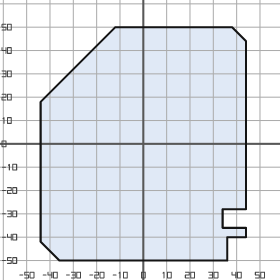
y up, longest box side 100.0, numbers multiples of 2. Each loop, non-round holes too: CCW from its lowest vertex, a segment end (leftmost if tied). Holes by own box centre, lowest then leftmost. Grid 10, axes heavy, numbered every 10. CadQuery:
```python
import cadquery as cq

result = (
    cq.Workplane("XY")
    .moveTo(-36.0, -50.0)
    .lineTo(36.0, -50.0)
    .lineTo(36.0, -40.0)
    .lineTo(44.0, -40.0)
    .lineTo(44.0, -36.0)
    .lineTo(34.0, -36.0)
    .lineTo(34.0, -28.0)
    .lineTo(44.0, -28.0)
    .lineTo(44.0, 44.0)
    .lineTo(38.0, 50.0)
    .lineTo(-12.0, 50.0)
    .lineTo(-44.0, 18.0)
    .lineTo(-44.0, -42.0)
    .close()
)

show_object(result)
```